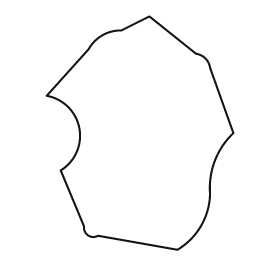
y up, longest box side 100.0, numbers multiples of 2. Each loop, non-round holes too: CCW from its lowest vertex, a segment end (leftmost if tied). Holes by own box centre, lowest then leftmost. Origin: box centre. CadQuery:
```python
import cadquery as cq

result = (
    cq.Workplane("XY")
    .moveTo(16.0, -50.0)
    .threePointArc((26.0, -40.0), (30.0, -26.0))
    .threePointArc((32.0, -12.0), (40.0, 0.0))
    .lineTo(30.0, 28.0)
    .threePointArc((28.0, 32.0), (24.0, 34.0))
    .lineTo(4.0, 50.0)
    .lineTo(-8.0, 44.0)
    .threePointArc((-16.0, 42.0), (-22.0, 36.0))
    .lineTo(-40.0, 16.0)
    .threePointArc((-26.0, 2.0), (-34.0, -16.0))
    .lineTo(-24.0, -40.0)
    .threePointArc((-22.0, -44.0), (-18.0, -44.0))
    .close()
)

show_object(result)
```